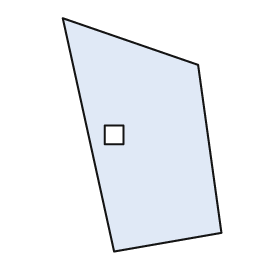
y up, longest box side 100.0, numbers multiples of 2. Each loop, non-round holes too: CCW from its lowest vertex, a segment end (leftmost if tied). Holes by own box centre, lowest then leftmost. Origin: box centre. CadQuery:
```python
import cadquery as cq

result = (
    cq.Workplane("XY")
    .moveTo(-12.0, -50.0)
    .lineTo(34.0, -42.0)
    .lineTo(24.0, 30.0)
    .lineTo(-34.0, 50.0)
    .close()
    .moveTo(-16.0, -4.0)
    .lineTo(-8.0, -4.0)
    .lineTo(-8.0, 4.0)
    .lineTo(-16.0, 4.0)
    .close()
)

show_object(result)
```